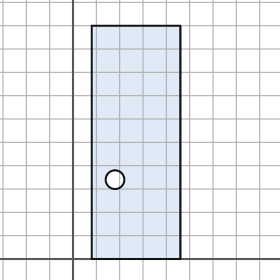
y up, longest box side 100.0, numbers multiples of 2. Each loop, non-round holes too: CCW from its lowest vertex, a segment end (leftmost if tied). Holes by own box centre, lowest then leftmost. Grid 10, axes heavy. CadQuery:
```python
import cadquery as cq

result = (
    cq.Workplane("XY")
    .moveTo(8.0, 0.0)
    .lineTo(46.0, 0.0)
    .lineTo(46.0, 100.0)
    .lineTo(8.0, 100.0)
    .close()
    .moveTo(18.0, 34.0)
    .circle(4.0)
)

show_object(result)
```